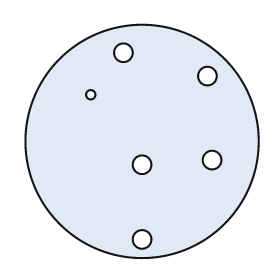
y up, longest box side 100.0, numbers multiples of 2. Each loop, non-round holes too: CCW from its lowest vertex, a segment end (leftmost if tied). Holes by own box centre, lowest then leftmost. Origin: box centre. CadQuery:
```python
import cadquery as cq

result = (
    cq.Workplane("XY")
    .moveTo(0.0, 0.0)
    .circle(50.0)
    .moveTo(0.0, -42.0)
    .circle(4.0)
    .moveTo(0.0, -10.0)
    .circle(4.0)
    .moveTo(30.0, -8.0)
    .circle(4.0)
    .moveTo(-22.0, 20.0)
    .circle(2.0)
    .moveTo(28.0, 28.0)
    .circle(4.0)
    .moveTo(-8.0, 38.0)
    .circle(4.0)
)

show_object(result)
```